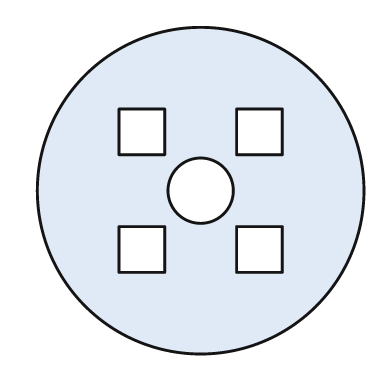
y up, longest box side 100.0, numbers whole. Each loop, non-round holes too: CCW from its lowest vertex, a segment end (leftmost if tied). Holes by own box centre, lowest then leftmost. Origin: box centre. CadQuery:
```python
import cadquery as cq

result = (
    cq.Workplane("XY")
    .moveTo(0.0, 0.0)
    .circle(50.0)
    .moveTo(-25.0, -25.0)
    .lineTo(-11.0, -25.0)
    .lineTo(-11.0, -11.0)
    .lineTo(-25.0, -11.0)
    .close()
    .moveTo(11.0, -25.0)
    .lineTo(25.0, -25.0)
    .lineTo(25.0, -11.0)
    .lineTo(11.0, -11.0)
    .close()
    .moveTo(0.0, 0.0)
    .circle(10.0)
    .moveTo(-25.0, 11.0)
    .lineTo(-11.0, 11.0)
    .lineTo(-11.0, 25.0)
    .lineTo(-25.0, 25.0)
    .close()
    .moveTo(11.0, 11.0)
    .lineTo(25.0, 11.0)
    .lineTo(25.0, 25.0)
    .lineTo(11.0, 25.0)
    .close()
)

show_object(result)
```